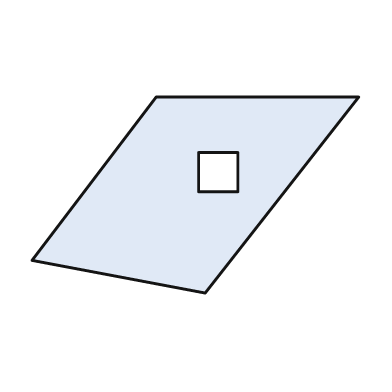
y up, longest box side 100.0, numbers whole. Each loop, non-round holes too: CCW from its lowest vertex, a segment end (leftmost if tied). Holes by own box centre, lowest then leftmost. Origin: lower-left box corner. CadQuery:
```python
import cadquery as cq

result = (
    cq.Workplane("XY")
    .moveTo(53.0, 0.0)
    .lineTo(100.0, 60.0)
    .lineTo(38.0, 60.0)
    .lineTo(0.0, 10.0)
    .close()
    .moveTo(51.0, 31.0)
    .lineTo(63.0, 31.0)
    .lineTo(63.0, 43.0)
    .lineTo(51.0, 43.0)
    .close()
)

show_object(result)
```